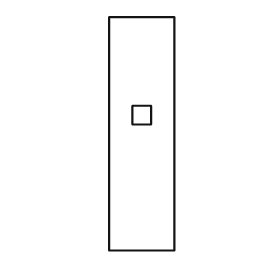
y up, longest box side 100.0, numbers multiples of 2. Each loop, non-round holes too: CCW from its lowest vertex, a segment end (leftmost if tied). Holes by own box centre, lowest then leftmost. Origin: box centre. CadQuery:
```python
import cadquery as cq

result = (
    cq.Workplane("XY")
    .moveTo(-14.0, -50.0)
    .lineTo(14.0, -50.0)
    .lineTo(14.0, 50.0)
    .lineTo(-14.0, 50.0)
    .close()
    .moveTo(-4.0, 4.0)
    .lineTo(4.0, 4.0)
    .lineTo(4.0, 12.0)
    .lineTo(-4.0, 12.0)
    .close()
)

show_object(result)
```